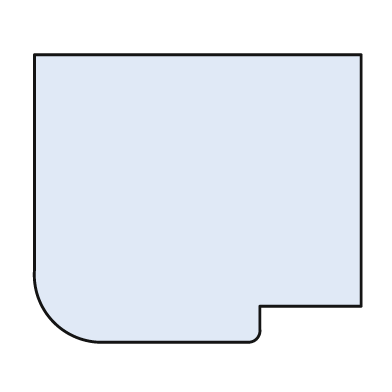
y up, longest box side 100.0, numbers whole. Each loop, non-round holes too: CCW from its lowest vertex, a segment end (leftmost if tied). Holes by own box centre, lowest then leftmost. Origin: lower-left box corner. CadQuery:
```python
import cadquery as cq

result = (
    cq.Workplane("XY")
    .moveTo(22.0, 0.0)
    .lineTo(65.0, 0.0)
    .threePointArc((68.0, 1.0), (69.0, 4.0))
    .lineTo(69.0, 11.0)
    .lineTo(100.0, 11.0)
    .lineTo(100.0, 88.0)
    .lineTo(0.0, 88.0)
    .lineTo(0.0, 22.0)
    .threePointArc((6.0, 6.0), (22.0, 0.0))
    .close()
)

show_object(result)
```